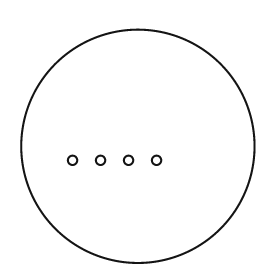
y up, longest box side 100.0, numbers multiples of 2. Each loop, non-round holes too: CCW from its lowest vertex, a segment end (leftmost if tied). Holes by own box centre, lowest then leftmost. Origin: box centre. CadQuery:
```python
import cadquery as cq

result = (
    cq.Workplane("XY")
    .moveTo(0.0, 0.0)
    .circle(50.0)
    .moveTo(-28.0, -6.0)
    .circle(2.0)
    .moveTo(-16.0, -6.0)
    .circle(2.0)
    .moveTo(-4.0, -6.0)
    .circle(2.0)
    .moveTo(8.0, -6.0)
    .circle(2.0)
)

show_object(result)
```